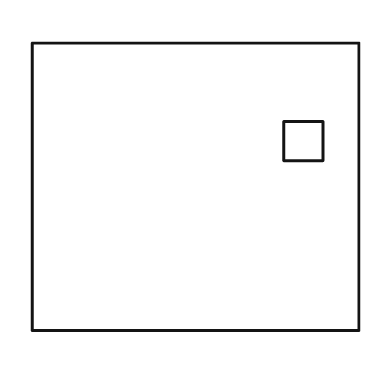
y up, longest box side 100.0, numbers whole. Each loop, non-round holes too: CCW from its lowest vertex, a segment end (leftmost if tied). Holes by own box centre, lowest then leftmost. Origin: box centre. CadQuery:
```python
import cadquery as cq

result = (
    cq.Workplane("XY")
    .moveTo(-50.0, -44.0)
    .lineTo(50.0, -44.0)
    .lineTo(50.0, 44.0)
    .lineTo(-50.0, 44.0)
    .close()
    .moveTo(27.0, 8.0)
    .lineTo(39.0, 8.0)
    .lineTo(39.0, 20.0)
    .lineTo(27.0, 20.0)
    .close()
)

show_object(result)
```